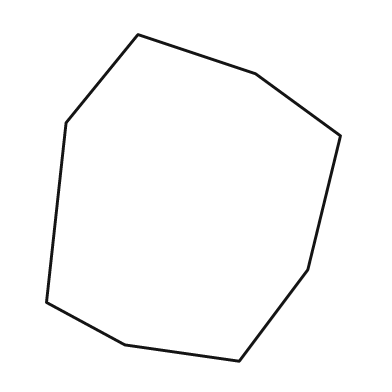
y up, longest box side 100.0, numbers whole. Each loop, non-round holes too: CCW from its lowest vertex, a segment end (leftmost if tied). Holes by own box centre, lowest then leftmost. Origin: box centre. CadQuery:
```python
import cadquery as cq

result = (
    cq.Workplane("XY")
    .moveTo(14.0, -50.0)
    .lineTo(35.0, -22.0)
    .lineTo(45.0, 19.0)
    .lineTo(19.0, 38.0)
    .lineTo(-17.0, 50.0)
    .lineTo(-39.0, 23.0)
    .lineTo(-45.0, -32.0)
    .lineTo(-21.0, -45.0)
    .close()
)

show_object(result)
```